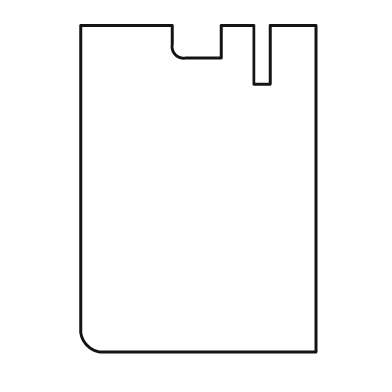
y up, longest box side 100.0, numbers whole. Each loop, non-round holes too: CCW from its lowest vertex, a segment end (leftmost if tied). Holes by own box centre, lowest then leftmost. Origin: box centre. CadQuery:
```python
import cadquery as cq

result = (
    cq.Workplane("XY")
    .moveTo(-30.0, -50.0)
    .lineTo(36.0, -50.0)
    .lineTo(36.0, 50.0)
    .lineTo(22.0, 50.0)
    .lineTo(22.0, 32.0)
    .lineTo(17.0, 32.0)
    .lineTo(17.0, 50.0)
    .lineTo(7.0, 50.0)
    .lineTo(7.0, 40.0)
    .lineTo(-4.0, 40.0)
    .threePointArc((-7.0, 41.0), (-8.0, 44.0))
    .lineTo(-8.0, 50.0)
    .lineTo(-36.0, 50.0)
    .lineTo(-36.0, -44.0)
    .threePointArc((-34.0, -48.0), (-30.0, -50.0))
    .close()
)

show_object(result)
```